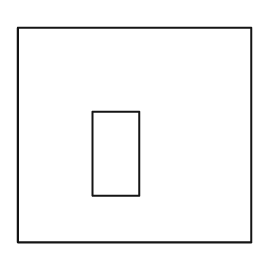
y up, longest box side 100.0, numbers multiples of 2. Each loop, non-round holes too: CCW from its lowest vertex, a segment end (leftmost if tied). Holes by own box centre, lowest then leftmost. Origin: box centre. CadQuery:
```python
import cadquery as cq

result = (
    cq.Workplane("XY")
    .moveTo(-50.0, -46.0)
    .lineTo(50.0, -46.0)
    .lineTo(50.0, 46.0)
    .lineTo(-50.0, 46.0)
    .close()
    .moveTo(-18.0, -26.0)
    .lineTo(2.0, -26.0)
    .lineTo(2.0, 10.0)
    .lineTo(-18.0, 10.0)
    .close()
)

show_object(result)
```